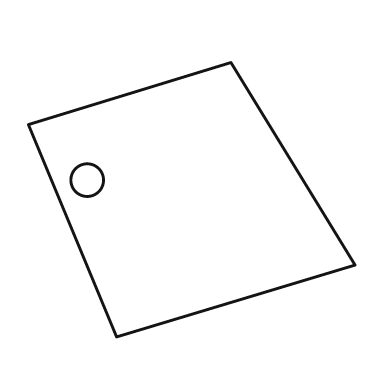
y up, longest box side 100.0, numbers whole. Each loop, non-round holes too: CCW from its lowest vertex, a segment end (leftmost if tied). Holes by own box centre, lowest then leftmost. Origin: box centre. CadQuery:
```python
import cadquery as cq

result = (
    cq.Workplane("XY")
    .moveTo(-23.0, -42.0)
    .lineTo(50.0, -20.0)
    .lineTo(12.0, 42.0)
    .lineTo(-50.0, 23.0)
    .close()
    .moveTo(-32.0, 6.0)
    .circle(5.0)
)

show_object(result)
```